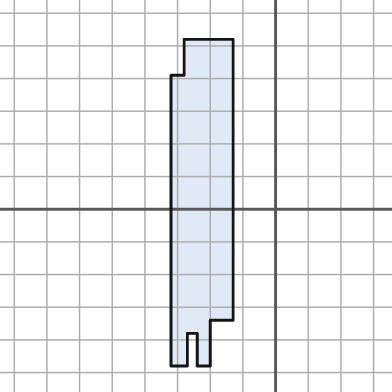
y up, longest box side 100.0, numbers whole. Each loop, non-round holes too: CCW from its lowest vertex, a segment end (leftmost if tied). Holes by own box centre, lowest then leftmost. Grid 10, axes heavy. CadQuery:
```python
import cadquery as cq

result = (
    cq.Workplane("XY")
    .moveTo(-32.0, -48.0)
    .lineTo(-27.0, -48.0)
    .lineTo(-27.0, -38.0)
    .lineTo(-24.0, -38.0)
    .lineTo(-24.0, -48.0)
    .lineTo(-20.0, -48.0)
    .lineTo(-20.0, -34.0)
    .lineTo(-13.0, -34.0)
    .lineTo(-13.0, 52.0)
    .lineTo(-28.0, 52.0)
    .lineTo(-28.0, 41.0)
    .lineTo(-32.0, 41.0)
    .close()
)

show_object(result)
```